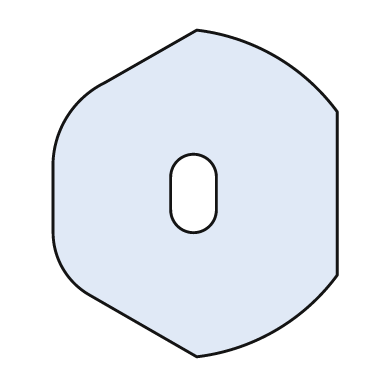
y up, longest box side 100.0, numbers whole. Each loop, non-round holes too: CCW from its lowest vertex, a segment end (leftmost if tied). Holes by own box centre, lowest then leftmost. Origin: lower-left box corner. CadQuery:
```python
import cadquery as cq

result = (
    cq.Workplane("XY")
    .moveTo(44.0, 0.0)
    .threePointArc((68.0, 8.0), (87.0, 25.0))
    .lineTo(87.0, 75.0)
    .threePointArc((68.0, 92.0), (44.0, 100.0))
    .lineTo(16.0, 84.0)
    .threePointArc((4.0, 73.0), (0.0, 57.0))
    .lineTo(0.0, 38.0)
    .threePointArc((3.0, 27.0), (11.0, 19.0))
    .close()
    .moveTo(36.0, 45.0)
    .threePointArc((43.0, 38.0), (50.0, 45.0))
    .lineTo(50.0, 55.0)
    .threePointArc((43.0, 62.0), (36.0, 55.0))
    .close()
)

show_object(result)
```